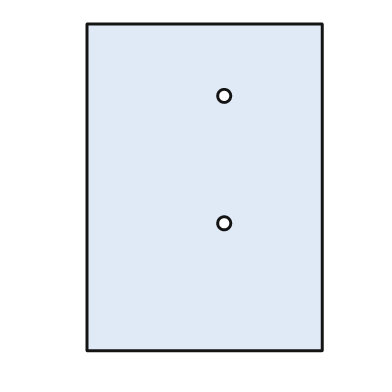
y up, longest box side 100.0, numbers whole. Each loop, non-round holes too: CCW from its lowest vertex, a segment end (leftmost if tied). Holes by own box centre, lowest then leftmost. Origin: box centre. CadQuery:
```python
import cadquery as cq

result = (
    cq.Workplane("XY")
    .moveTo(-36.0, -50.0)
    .lineTo(36.0, -50.0)
    .lineTo(36.0, 50.0)
    .lineTo(-36.0, 50.0)
    .close()
    .moveTo(6.0, -11.0)
    .circle(2.0)
    .moveTo(6.0, 28.0)
    .circle(2.0)
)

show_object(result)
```